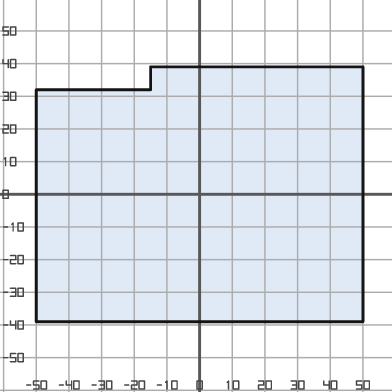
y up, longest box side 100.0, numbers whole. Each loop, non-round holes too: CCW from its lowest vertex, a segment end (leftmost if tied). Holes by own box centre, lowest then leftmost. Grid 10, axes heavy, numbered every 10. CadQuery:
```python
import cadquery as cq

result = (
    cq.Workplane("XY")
    .moveTo(-50.0, -39.0)
    .lineTo(50.0, -39.0)
    .lineTo(50.0, 39.0)
    .lineTo(-15.0, 39.0)
    .lineTo(-15.0, 32.0)
    .lineTo(-50.0, 32.0)
    .close()
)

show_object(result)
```